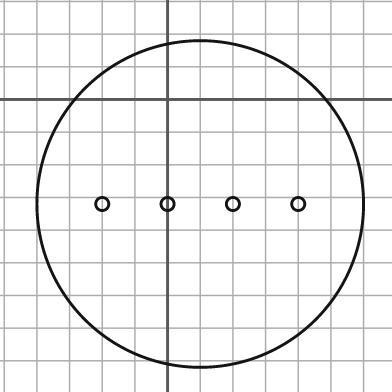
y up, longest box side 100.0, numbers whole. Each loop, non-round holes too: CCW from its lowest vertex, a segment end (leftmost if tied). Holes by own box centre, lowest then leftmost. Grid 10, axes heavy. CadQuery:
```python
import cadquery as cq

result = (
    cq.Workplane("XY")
    .moveTo(10.0, -32.0)
    .circle(50.0)
    .moveTo(-20.0, -32.0)
    .circle(2.0)
    .moveTo(0.0, -32.0)
    .circle(2.0)
    .moveTo(20.0, -32.0)
    .circle(2.0)
    .moveTo(40.0, -32.0)
    .circle(2.0)
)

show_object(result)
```